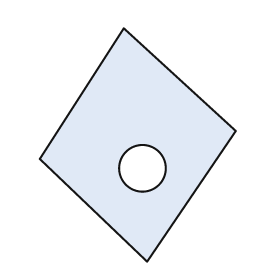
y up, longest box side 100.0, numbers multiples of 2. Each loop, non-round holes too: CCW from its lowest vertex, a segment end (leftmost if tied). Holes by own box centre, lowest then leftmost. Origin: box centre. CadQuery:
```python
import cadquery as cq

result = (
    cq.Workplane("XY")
    .moveTo(4.0, -50.0)
    .lineTo(42.0, 6.0)
    .lineTo(-6.0, 50.0)
    .lineTo(-42.0, -6.0)
    .close()
    .moveTo(2.0, -10.0)
    .circle(10.0)
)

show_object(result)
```